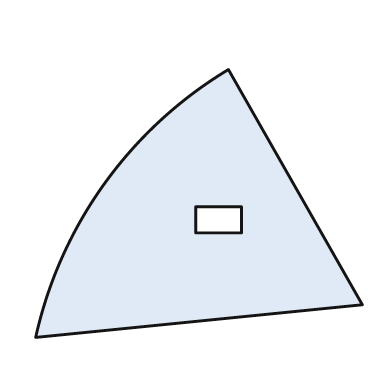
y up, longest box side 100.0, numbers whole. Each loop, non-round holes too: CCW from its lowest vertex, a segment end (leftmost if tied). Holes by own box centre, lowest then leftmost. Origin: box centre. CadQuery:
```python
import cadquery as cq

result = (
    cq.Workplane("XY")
    .moveTo(-50.0, -41.0)
    .lineTo(50.0, -31.0)
    .lineTo(9.0, 41.0)
    .threePointArc((-29.0, 6.0), (-50.0, -41.0))
    .close()
    .moveTo(-1.0, -9.0)
    .lineTo(13.0, -9.0)
    .lineTo(13.0, -1.0)
    .lineTo(-1.0, -1.0)
    .close()
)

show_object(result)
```